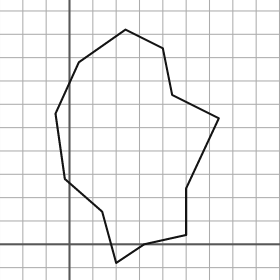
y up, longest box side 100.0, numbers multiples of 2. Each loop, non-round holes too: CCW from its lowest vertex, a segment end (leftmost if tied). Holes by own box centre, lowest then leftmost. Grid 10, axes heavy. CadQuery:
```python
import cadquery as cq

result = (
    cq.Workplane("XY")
    .moveTo(20.0, -8.0)
    .lineTo(32.0, 0.0)
    .lineTo(50.0, 4.0)
    .lineTo(50.0, 24.0)
    .lineTo(64.0, 54.0)
    .lineTo(44.0, 64.0)
    .lineTo(40.0, 84.0)
    .lineTo(24.0, 92.0)
    .lineTo(4.0, 78.0)
    .lineTo(-6.0, 56.0)
    .lineTo(-2.0, 28.0)
    .lineTo(14.0, 14.0)
    .close()
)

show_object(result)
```